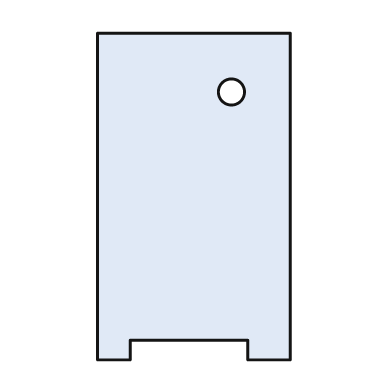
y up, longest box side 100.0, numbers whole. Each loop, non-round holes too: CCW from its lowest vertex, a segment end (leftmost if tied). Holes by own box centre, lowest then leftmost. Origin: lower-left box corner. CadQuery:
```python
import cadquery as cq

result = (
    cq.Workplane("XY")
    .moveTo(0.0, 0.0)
    .lineTo(10.0, 0.0)
    .lineTo(10.0, 6.0)
    .lineTo(46.0, 6.0)
    .lineTo(46.0, 0.0)
    .lineTo(59.0, 0.0)
    .lineTo(59.0, 100.0)
    .lineTo(0.0, 100.0)
    .close()
    .moveTo(41.0, 82.0)
    .circle(4.0)
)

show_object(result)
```